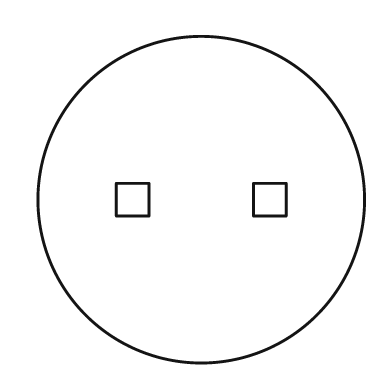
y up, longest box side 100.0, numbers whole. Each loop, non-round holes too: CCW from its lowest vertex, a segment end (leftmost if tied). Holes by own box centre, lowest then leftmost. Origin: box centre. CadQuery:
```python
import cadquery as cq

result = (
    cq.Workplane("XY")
    .moveTo(0.0, 0.0)
    .circle(50.0)
    .moveTo(-26.0, -5.0)
    .lineTo(-16.0, -5.0)
    .lineTo(-16.0, 5.0)
    .lineTo(-26.0, 5.0)
    .close()
    .moveTo(16.0, -5.0)
    .lineTo(26.0, -5.0)
    .lineTo(26.0, 5.0)
    .lineTo(16.0, 5.0)
    .close()
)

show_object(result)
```